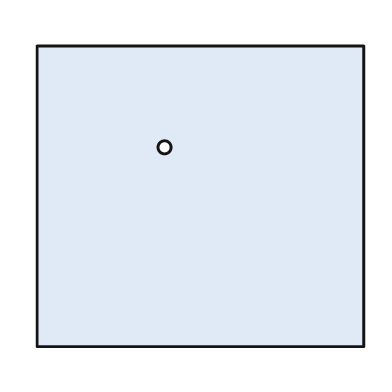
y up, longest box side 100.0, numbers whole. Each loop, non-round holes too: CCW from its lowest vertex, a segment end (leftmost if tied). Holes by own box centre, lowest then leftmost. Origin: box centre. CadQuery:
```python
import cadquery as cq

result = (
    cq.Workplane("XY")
    .moveTo(-50.0, -46.0)
    .lineTo(50.0, -46.0)
    .lineTo(50.0, 46.0)
    .lineTo(-50.0, 46.0)
    .close()
    .moveTo(-11.0, 15.0)
    .circle(2.0)
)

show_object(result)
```